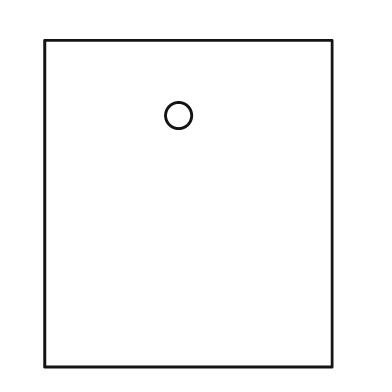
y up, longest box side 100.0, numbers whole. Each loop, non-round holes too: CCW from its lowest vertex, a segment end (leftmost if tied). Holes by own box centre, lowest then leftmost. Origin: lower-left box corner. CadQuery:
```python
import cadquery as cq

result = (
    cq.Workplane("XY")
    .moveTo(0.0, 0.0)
    .lineTo(88.0, 0.0)
    .lineTo(88.0, 100.0)
    .lineTo(0.0, 100.0)
    .close()
    .moveTo(41.0, 77.0)
    .circle(4.0)
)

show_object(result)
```